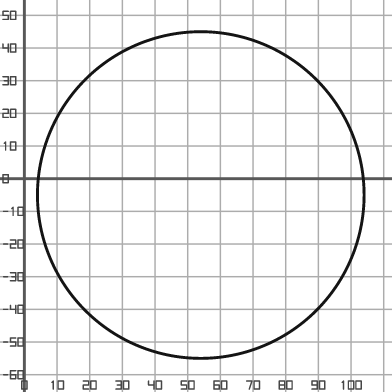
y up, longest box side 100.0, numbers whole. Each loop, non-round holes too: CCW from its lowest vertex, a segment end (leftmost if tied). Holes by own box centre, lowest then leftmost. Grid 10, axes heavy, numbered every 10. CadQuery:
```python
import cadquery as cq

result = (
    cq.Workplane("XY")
    .moveTo(54.0, -5.0)
    .circle(50.0)
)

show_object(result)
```